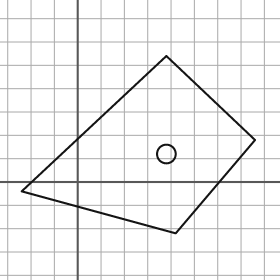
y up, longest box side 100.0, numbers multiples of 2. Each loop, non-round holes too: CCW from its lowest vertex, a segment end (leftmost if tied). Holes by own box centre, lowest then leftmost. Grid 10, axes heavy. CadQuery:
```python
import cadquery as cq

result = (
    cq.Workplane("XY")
    .moveTo(42.0, -22.0)
    .lineTo(76.0, 18.0)
    .lineTo(38.0, 54.0)
    .lineTo(-24.0, -4.0)
    .close()
    .moveTo(38.0, 12.0)
    .circle(4.0)
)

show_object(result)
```